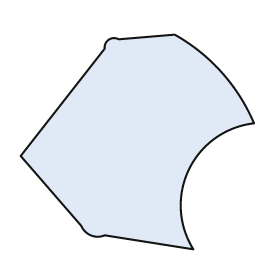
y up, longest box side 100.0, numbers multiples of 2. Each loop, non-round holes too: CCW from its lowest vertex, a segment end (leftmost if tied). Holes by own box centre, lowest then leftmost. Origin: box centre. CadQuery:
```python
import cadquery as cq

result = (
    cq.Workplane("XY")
    .moveTo(24.0, -46.0)
    .threePointArc((22.0, -12.0), (50.0, 8.0))
    .threePointArc((36.0, 30.0), (16.0, 46.0))
    .lineTo(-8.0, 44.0)
    .threePointArc((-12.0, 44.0), (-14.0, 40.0))
    .lineTo(-50.0, -6.0)
    .lineTo(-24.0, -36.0)
    .threePointArc((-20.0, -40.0), (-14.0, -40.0))
    .close()
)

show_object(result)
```